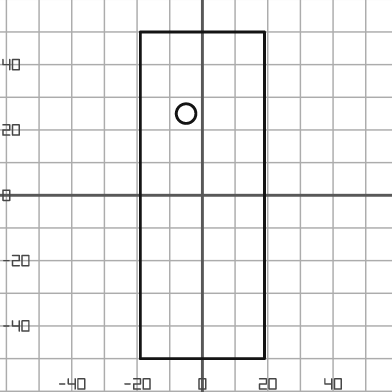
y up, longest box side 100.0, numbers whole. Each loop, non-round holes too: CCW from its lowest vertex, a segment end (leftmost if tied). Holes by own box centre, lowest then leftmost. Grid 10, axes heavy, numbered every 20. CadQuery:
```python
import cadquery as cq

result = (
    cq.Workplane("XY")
    .moveTo(-19.0, -50.0)
    .lineTo(19.0, -50.0)
    .lineTo(19.0, 50.0)
    .lineTo(-19.0, 50.0)
    .close()
    .moveTo(-5.0, 25.0)
    .circle(3.0)
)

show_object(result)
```